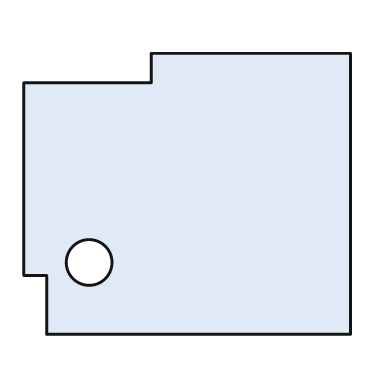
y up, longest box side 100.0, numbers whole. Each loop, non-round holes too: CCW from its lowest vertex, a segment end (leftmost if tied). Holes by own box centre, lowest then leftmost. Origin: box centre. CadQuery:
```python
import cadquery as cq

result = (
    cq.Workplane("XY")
    .moveTo(-43.0, -43.0)
    .lineTo(50.0, -43.0)
    .lineTo(50.0, 43.0)
    .lineTo(-11.0, 43.0)
    .lineTo(-11.0, 34.0)
    .lineTo(-50.0, 34.0)
    .lineTo(-50.0, -25.0)
    .lineTo(-43.0, -25.0)
    .close()
    .moveTo(-30.0, -21.0)
    .circle(7.0)
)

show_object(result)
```